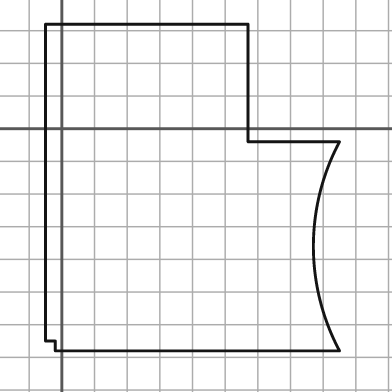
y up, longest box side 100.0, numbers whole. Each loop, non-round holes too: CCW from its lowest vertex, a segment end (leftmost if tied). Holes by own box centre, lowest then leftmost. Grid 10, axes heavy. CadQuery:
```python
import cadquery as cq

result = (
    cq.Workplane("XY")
    .moveTo(-2.0, -68.0)
    .lineTo(85.0, -68.0)
    .threePointArc((77.0, -36.0), (85.0, -4.0))
    .lineTo(57.0, -4.0)
    .lineTo(57.0, 32.0)
    .lineTo(-5.0, 32.0)
    .lineTo(-5.0, -65.0)
    .lineTo(-2.0, -65.0)
    .close()
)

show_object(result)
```